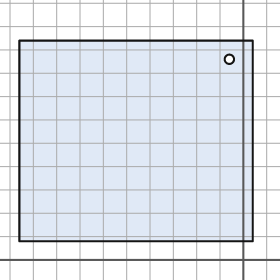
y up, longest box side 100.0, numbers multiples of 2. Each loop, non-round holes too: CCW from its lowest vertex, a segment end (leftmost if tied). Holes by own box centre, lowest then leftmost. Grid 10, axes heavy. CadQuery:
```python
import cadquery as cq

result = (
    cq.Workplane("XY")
    .moveTo(-96.0, 8.0)
    .lineTo(4.0, 8.0)
    .lineTo(4.0, 94.0)
    .lineTo(-96.0, 94.0)
    .close()
    .moveTo(-6.0, 86.0)
    .circle(2.0)
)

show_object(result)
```